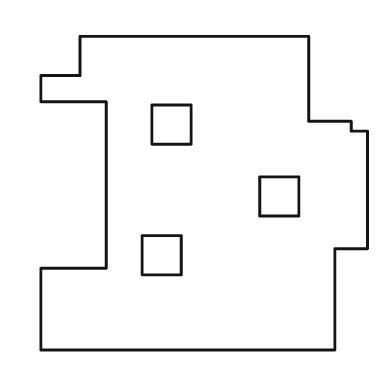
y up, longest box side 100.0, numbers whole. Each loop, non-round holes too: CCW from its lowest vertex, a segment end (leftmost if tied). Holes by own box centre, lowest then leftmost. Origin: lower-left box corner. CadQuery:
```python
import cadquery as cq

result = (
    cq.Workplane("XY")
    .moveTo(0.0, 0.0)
    .lineTo(90.0, 0.0)
    .lineTo(90.0, 31.0)
    .lineTo(100.0, 31.0)
    .lineTo(100.0, 67.0)
    .lineTo(95.0, 67.0)
    .lineTo(95.0, 70.0)
    .lineTo(82.0, 70.0)
    .lineTo(82.0, 96.0)
    .lineTo(12.0, 96.0)
    .lineTo(12.0, 84.0)
    .lineTo(0.0, 84.0)
    .lineTo(0.0, 76.0)
    .lineTo(20.0, 76.0)
    .lineTo(20.0, 25.0)
    .lineTo(0.0, 25.0)
    .close()
    .moveTo(31.0, 23.0)
    .lineTo(43.0, 23.0)
    .lineTo(43.0, 35.0)
    .lineTo(31.0, 35.0)
    .close()
    .moveTo(67.0, 41.0)
    .lineTo(79.0, 41.0)
    .lineTo(79.0, 53.0)
    .lineTo(67.0, 53.0)
    .close()
    .moveTo(34.0, 63.0)
    .lineTo(46.0, 63.0)
    .lineTo(46.0, 75.0)
    .lineTo(34.0, 75.0)
    .close()
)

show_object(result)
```